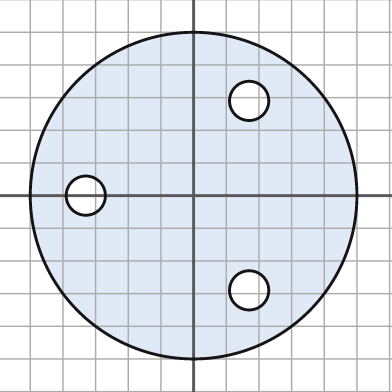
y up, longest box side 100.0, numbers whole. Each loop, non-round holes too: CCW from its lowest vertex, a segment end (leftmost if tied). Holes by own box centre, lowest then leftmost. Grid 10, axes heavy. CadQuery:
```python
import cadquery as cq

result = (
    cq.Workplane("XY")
    .moveTo(0.0, 0.0)
    .circle(50.0)
    .moveTo(17.0, -29.0)
    .circle(6.0)
    .moveTo(-33.0, 0.0)
    .circle(6.0)
    .moveTo(17.0, 29.0)
    .circle(6.0)
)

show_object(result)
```